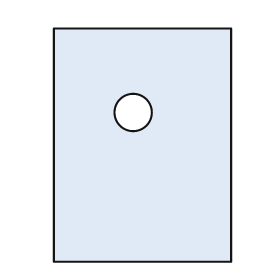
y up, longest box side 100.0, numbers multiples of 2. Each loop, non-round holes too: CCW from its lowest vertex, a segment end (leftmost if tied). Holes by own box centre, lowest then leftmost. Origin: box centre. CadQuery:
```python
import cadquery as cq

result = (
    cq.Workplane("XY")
    .moveTo(-38.0, -50.0)
    .lineTo(38.0, -50.0)
    .lineTo(38.0, 50.0)
    .lineTo(-38.0, 50.0)
    .close()
    .moveTo(-4.0, 14.0)
    .circle(8.0)
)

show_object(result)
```